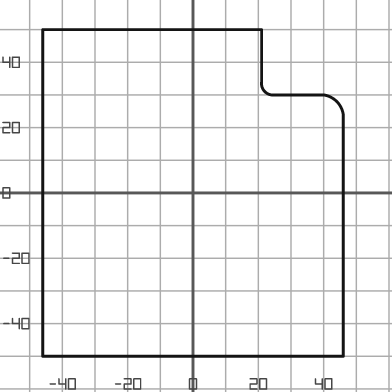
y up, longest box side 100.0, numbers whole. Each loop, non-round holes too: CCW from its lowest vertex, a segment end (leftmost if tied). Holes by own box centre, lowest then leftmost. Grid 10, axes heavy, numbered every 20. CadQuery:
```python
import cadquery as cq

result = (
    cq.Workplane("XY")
    .moveTo(-46.0, -50.0)
    .lineTo(46.0, -50.0)
    .lineTo(46.0, 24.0)
    .threePointArc((44.0, 28.0), (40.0, 30.0))
    .lineTo(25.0, 30.0)
    .threePointArc((22.0, 31.0), (21.0, 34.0))
    .lineTo(21.0, 50.0)
    .lineTo(-46.0, 50.0)
    .close()
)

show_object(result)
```